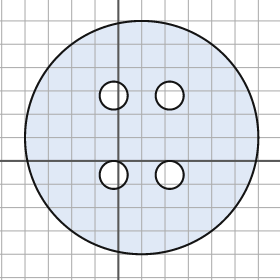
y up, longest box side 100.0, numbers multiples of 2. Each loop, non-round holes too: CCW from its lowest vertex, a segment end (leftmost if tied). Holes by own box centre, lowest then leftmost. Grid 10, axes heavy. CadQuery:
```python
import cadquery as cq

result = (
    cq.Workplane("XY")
    .moveTo(10.0, 10.0)
    .circle(50.0)
    .moveTo(-2.0, -6.0)
    .circle(6.0)
    .moveTo(22.0, -6.0)
    .circle(6.0)
    .moveTo(-2.0, 28.0)
    .circle(6.0)
    .moveTo(22.0, 28.0)
    .circle(6.0)
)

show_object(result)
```